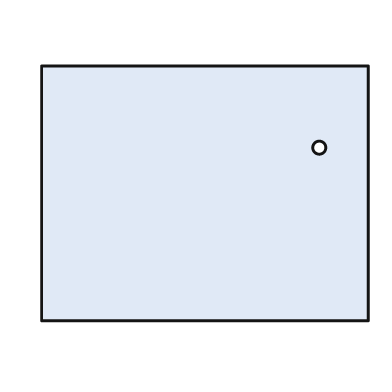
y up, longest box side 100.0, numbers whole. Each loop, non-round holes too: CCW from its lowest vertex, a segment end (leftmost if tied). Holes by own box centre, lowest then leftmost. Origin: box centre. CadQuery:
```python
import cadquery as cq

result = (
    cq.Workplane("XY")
    .moveTo(-50.0, -39.0)
    .lineTo(50.0, -39.0)
    .lineTo(50.0, 39.0)
    .lineTo(-50.0, 39.0)
    .close()
    .moveTo(35.0, 14.0)
    .circle(2.0)
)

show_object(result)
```